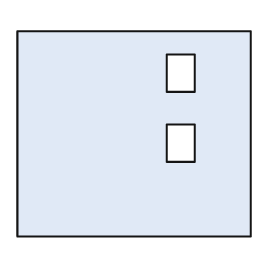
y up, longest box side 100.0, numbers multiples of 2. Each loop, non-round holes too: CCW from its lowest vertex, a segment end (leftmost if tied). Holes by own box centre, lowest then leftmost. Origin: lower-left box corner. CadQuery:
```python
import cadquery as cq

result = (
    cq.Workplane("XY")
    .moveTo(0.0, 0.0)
    .lineTo(100.0, 0.0)
    .lineTo(100.0, 88.0)
    .lineTo(0.0, 88.0)
    .close()
    .moveTo(64.0, 32.0)
    .lineTo(76.0, 32.0)
    .lineTo(76.0, 48.0)
    .lineTo(64.0, 48.0)
    .close()
    .moveTo(64.0, 62.0)
    .lineTo(76.0, 62.0)
    .lineTo(76.0, 78.0)
    .lineTo(64.0, 78.0)
    .close()
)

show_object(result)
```